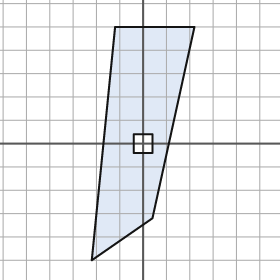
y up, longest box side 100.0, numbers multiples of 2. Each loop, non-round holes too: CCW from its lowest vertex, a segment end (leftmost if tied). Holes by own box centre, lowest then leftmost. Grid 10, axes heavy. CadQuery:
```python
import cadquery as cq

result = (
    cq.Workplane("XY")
    .moveTo(-22.0, -50.0)
    .lineTo(4.0, -32.0)
    .lineTo(22.0, 50.0)
    .lineTo(-12.0, 50.0)
    .close()
    .moveTo(-4.0, -4.0)
    .lineTo(4.0, -4.0)
    .lineTo(4.0, 4.0)
    .lineTo(-4.0, 4.0)
    .close()
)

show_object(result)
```